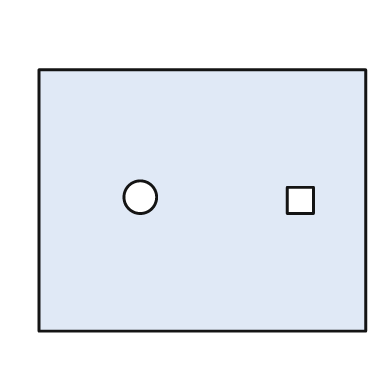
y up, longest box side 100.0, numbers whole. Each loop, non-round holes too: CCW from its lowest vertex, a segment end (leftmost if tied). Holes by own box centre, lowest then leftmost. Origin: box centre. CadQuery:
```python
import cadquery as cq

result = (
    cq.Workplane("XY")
    .moveTo(-50.0, -40.0)
    .lineTo(50.0, -40.0)
    .lineTo(50.0, 40.0)
    .lineTo(-50.0, 40.0)
    .close()
    .moveTo(26.0, -4.0)
    .lineTo(34.0, -4.0)
    .lineTo(34.0, 4.0)
    .lineTo(26.0, 4.0)
    .close()
    .moveTo(-19.0, 1.0)
    .circle(5.0)
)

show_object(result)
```